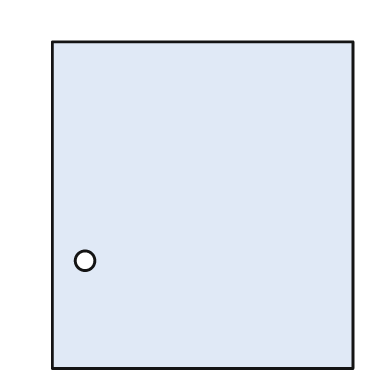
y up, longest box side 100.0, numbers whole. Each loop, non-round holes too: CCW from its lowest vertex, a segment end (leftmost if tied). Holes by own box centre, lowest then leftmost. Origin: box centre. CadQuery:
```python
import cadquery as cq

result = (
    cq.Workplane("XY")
    .moveTo(-46.0, -50.0)
    .lineTo(46.0, -50.0)
    .lineTo(46.0, 50.0)
    .lineTo(-46.0, 50.0)
    .close()
    .moveTo(-36.0, -17.0)
    .circle(3.0)
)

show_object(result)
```